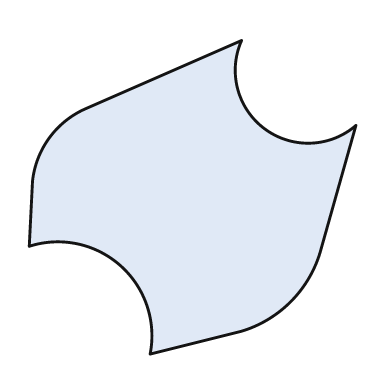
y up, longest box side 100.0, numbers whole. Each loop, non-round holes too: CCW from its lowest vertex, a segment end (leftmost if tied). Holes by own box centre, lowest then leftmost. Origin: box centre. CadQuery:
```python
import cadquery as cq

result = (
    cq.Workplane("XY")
    .moveTo(-13.0, -48.0)
    .lineTo(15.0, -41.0)
    .threePointArc((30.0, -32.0), (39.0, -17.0))
    .lineTo(50.0, 22.0)
    .threePointArc((22.0, 21.0), (15.0, 48.0))
    .lineTo(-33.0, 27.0)
    .threePointArc((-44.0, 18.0), (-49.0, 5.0))
    .lineTo(-50.0, -15.0)
    .threePointArc((-22.0, -21.0), (-13.0, -48.0))
    .close()
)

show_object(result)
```